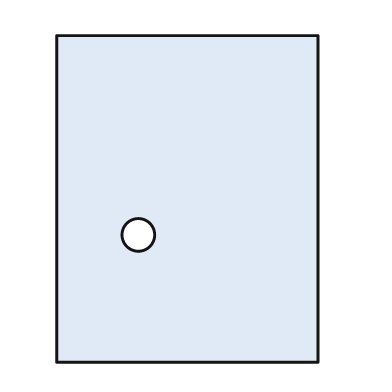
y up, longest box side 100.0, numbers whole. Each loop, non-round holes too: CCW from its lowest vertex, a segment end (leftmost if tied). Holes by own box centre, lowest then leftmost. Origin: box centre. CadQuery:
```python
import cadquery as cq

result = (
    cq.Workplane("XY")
    .moveTo(-40.0, -50.0)
    .lineTo(40.0, -50.0)
    .lineTo(40.0, 50.0)
    .lineTo(-40.0, 50.0)
    .close()
    .moveTo(-15.0, -11.0)
    .circle(5.0)
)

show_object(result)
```